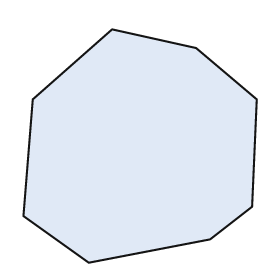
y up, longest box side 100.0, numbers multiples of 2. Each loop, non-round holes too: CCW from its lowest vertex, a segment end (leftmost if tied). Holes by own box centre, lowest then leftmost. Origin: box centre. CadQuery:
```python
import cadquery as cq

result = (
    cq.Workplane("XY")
    .moveTo(-22.0, -50.0)
    .lineTo(30.0, -40.0)
    .lineTo(48.0, -26.0)
    .lineTo(50.0, 20.0)
    .lineTo(24.0, 42.0)
    .lineTo(-12.0, 50.0)
    .lineTo(-46.0, 20.0)
    .lineTo(-50.0, -30.0)
    .close()
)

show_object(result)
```